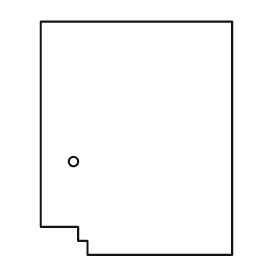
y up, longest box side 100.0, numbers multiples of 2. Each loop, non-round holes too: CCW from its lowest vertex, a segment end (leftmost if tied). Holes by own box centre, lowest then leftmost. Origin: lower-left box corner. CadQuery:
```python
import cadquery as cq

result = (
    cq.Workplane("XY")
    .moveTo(20.0, 0.0)
    .lineTo(82.0, 0.0)
    .lineTo(82.0, 100.0)
    .lineTo(0.0, 100.0)
    .lineTo(0.0, 12.0)
    .lineTo(16.0, 12.0)
    .lineTo(16.0, 6.0)
    .lineTo(20.0, 6.0)
    .close()
    .moveTo(14.0, 40.0)
    .circle(2.0)
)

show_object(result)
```